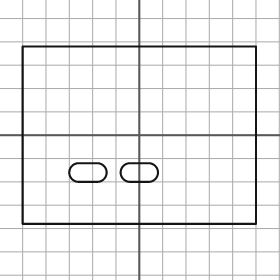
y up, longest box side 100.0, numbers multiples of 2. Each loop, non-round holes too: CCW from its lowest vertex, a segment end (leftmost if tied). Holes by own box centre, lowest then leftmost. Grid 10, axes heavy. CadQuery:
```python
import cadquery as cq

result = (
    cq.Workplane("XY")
    .moveTo(-50.0, -38.0)
    .lineTo(50.0, -38.0)
    .lineTo(50.0, 38.0)
    .lineTo(-50.0, 38.0)
    .close()
    .moveTo(-26.0, -20.0)
    .lineTo(-18.0, -20.0)
    .threePointArc((-14.0, -16.0), (-18.0, -12.0))
    .lineTo(-26.0, -12.0)
    .threePointArc((-30.0, -16.0), (-26.0, -20.0))
    .close()
    .moveTo(-4.0, -20.0)
    .lineTo(4.0, -20.0)
    .threePointArc((8.0, -16.0), (4.0, -12.0))
    .lineTo(-4.0, -12.0)
    .threePointArc((-8.0, -16.0), (-4.0, -20.0))
    .close()
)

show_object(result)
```